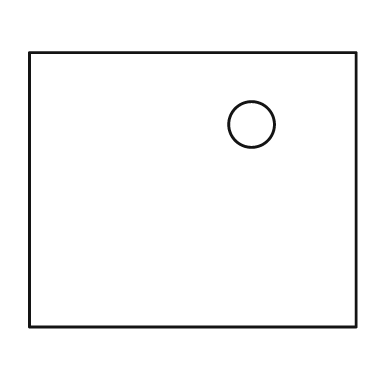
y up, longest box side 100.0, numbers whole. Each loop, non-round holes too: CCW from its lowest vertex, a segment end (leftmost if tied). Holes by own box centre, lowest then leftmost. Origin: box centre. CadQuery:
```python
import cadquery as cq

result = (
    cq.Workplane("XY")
    .moveTo(-50.0, -42.0)
    .lineTo(50.0, -42.0)
    .lineTo(50.0, 42.0)
    .lineTo(-50.0, 42.0)
    .close()
    .moveTo(18.0, 20.0)
    .circle(7.0)
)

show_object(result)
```